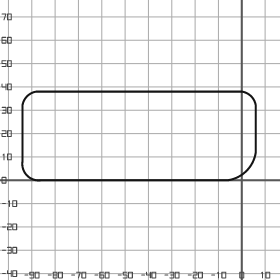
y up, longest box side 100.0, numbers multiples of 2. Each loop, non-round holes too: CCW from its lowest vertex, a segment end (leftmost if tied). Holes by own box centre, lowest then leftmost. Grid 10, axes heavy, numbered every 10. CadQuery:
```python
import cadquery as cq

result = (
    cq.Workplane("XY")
    .moveTo(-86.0, 0.0)
    .lineTo(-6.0, 0.0)
    .threePointArc((2.0, 4.0), (6.0, 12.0))
    .lineTo(6.0, 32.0)
    .threePointArc((4.0, 36.0), (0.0, 38.0))
    .lineTo(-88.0, 38.0)
    .threePointArc((-92.0, 36.0), (-94.0, 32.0))
    .lineTo(-94.0, 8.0)
    .threePointArc((-92.0, 2.0), (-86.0, 0.0))
    .close()
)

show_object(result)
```